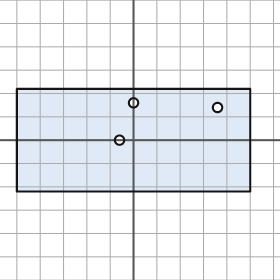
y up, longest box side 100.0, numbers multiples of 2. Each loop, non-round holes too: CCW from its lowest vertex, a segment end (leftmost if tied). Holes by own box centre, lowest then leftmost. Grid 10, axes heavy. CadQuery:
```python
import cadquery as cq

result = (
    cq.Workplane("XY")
    .moveTo(-50.0, -22.0)
    .lineTo(50.0, -22.0)
    .lineTo(50.0, 22.0)
    .lineTo(-50.0, 22.0)
    .close()
    .moveTo(-6.0, 0.0)
    .circle(2.0)
    .moveTo(36.0, 14.0)
    .circle(2.0)
    .moveTo(0.0, 16.0)
    .circle(2.0)
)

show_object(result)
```